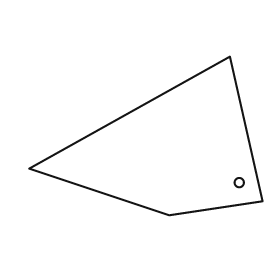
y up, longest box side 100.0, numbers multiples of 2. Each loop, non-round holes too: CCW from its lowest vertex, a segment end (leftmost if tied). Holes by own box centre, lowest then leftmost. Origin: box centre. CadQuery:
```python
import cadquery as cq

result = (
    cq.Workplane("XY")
    .moveTo(10.0, -34.0)
    .lineTo(50.0, -28.0)
    .lineTo(36.0, 34.0)
    .lineTo(-50.0, -14.0)
    .close()
    .moveTo(40.0, -20.0)
    .circle(2.0)
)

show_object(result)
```